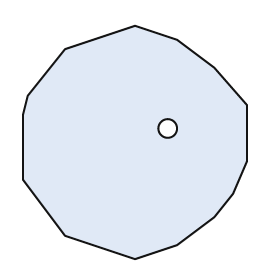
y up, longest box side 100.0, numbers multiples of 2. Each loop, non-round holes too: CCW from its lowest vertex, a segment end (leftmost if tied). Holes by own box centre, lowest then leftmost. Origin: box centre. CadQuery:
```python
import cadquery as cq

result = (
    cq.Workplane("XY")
    .moveTo(0.0, -50.0)
    .lineTo(18.0, -44.0)
    .lineTo(34.0, -32.0)
    .lineTo(42.0, -22.0)
    .lineTo(48.0, -8.0)
    .lineTo(48.0, 16.0)
    .lineTo(34.0, 32.0)
    .lineTo(18.0, 44.0)
    .lineTo(0.0, 50.0)
    .lineTo(-30.0, 40.0)
    .lineTo(-46.0, 20.0)
    .lineTo(-48.0, 12.0)
    .lineTo(-48.0, -16.0)
    .lineTo(-30.0, -40.0)
    .close()
    .moveTo(14.0, 6.0)
    .circle(4.0)
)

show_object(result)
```